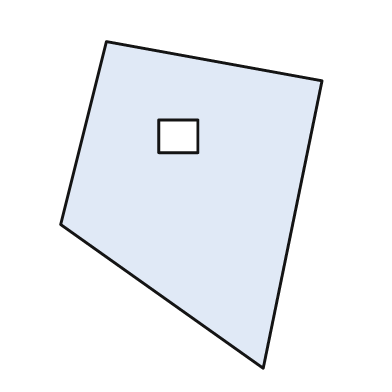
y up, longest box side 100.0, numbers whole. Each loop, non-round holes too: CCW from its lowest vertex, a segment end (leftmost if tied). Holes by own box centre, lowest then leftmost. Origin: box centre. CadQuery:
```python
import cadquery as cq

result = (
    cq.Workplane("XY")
    .moveTo(22.0, -50.0)
    .lineTo(40.0, 38.0)
    .lineTo(-26.0, 50.0)
    .lineTo(-40.0, -6.0)
    .close()
    .moveTo(-10.0, 16.0)
    .lineTo(2.0, 16.0)
    .lineTo(2.0, 26.0)
    .lineTo(-10.0, 26.0)
    .close()
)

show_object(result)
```